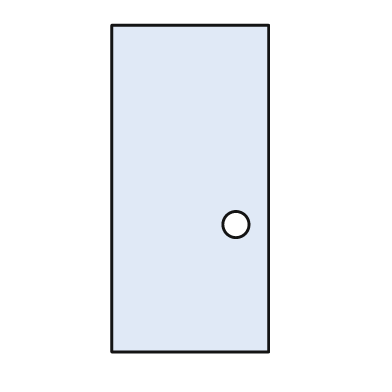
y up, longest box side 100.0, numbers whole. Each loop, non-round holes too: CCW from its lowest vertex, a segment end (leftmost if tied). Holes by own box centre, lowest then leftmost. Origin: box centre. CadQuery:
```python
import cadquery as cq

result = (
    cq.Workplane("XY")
    .moveTo(-24.0, -50.0)
    .lineTo(24.0, -50.0)
    .lineTo(24.0, 50.0)
    .lineTo(-24.0, 50.0)
    .close()
    .moveTo(14.0, -11.0)
    .circle(4.0)
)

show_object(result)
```